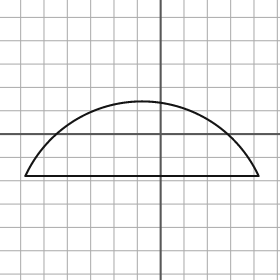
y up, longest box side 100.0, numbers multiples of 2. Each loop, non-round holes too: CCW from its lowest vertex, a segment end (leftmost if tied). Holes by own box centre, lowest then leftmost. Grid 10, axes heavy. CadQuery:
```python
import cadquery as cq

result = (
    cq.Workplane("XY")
    .moveTo(-58.0, -18.0)
    .lineTo(42.0, -18.0)
    .threePointArc((-8.0, 14.0), (-58.0, -18.0))
    .close()
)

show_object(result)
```